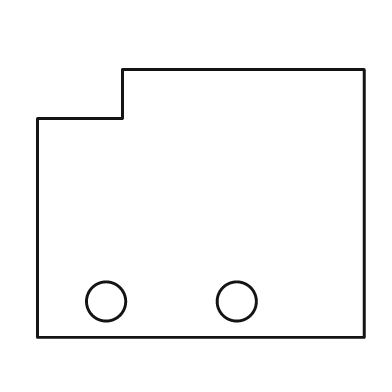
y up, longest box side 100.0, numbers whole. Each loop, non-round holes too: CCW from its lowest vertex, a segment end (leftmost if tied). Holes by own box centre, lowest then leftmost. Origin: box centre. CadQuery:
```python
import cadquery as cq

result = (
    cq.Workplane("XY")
    .moveTo(-50.0, -41.0)
    .lineTo(50.0, -41.0)
    .lineTo(50.0, 41.0)
    .lineTo(-24.0, 41.0)
    .lineTo(-24.0, 26.0)
    .lineTo(-50.0, 26.0)
    .close()
    .moveTo(-29.0, -30.0)
    .circle(6.0)
    .moveTo(11.0, -30.0)
    .circle(6.0)
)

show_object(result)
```